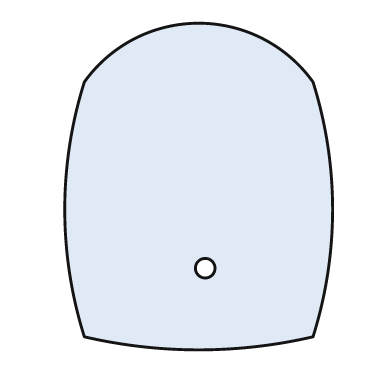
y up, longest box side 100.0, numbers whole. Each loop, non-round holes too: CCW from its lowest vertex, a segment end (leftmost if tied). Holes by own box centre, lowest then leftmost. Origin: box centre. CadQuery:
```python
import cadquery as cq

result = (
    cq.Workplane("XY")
    .moveTo(-35.0, -46.0)
    .threePointArc((0.0, -50.0), (35.0, -46.0))
    .threePointArc((41.0, -7.0), (35.0, 32.0))
    .threePointArc((0.0, 50.0), (-35.0, 32.0))
    .threePointArc((-41.0, -7.0), (-35.0, -46.0))
    .close()
    .moveTo(2.0, -25.0)
    .circle(3.0)
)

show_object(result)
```